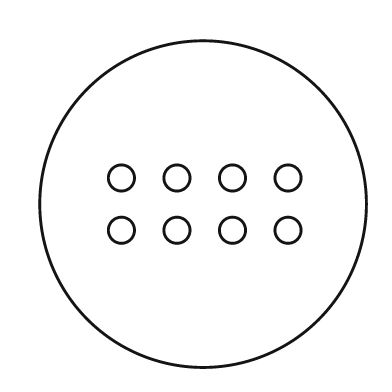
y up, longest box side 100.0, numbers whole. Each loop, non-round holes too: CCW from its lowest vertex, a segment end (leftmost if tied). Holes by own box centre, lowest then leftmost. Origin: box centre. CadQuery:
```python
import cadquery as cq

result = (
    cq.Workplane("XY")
    .moveTo(0.0, 0.0)
    .circle(50.0)
    .moveTo(-25.0, -8.0)
    .circle(4.0)
    .moveTo(-8.0, -8.0)
    .circle(4.0)
    .moveTo(9.0, -8.0)
    .circle(4.0)
    .moveTo(26.0, -8.0)
    .circle(4.0)
    .moveTo(-25.0, 8.0)
    .circle(4.0)
    .moveTo(-8.0, 8.0)
    .circle(4.0)
    .moveTo(9.0, 8.0)
    .circle(4.0)
    .moveTo(26.0, 8.0)
    .circle(4.0)
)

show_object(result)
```